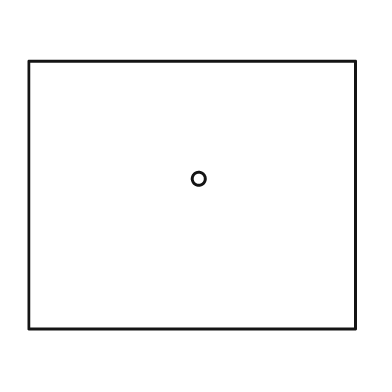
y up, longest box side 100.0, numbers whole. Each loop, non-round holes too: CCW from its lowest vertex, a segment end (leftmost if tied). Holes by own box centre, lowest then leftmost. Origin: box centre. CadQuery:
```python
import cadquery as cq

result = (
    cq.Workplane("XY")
    .moveTo(-50.0, -41.0)
    .lineTo(50.0, -41.0)
    .lineTo(50.0, 41.0)
    .lineTo(-50.0, 41.0)
    .close()
    .moveTo(2.0, 5.0)
    .circle(2.0)
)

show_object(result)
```